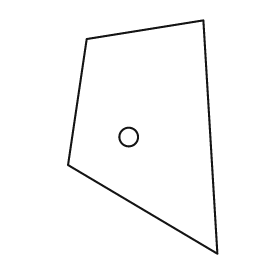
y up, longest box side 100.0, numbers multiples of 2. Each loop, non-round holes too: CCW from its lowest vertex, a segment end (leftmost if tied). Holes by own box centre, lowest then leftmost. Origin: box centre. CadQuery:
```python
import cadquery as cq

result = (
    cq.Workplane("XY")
    .moveTo(32.0, -50.0)
    .lineTo(26.0, 50.0)
    .lineTo(-24.0, 42.0)
    .lineTo(-32.0, -12.0)
    .close()
    .moveTo(-6.0, 0.0)
    .circle(4.0)
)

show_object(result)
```